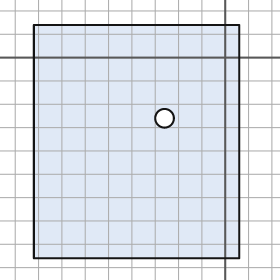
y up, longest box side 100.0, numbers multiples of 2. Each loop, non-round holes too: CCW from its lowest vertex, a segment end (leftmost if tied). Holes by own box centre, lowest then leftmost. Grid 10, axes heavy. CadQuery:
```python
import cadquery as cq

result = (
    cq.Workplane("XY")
    .moveTo(-82.0, -86.0)
    .lineTo(6.0, -86.0)
    .lineTo(6.0, 14.0)
    .lineTo(-82.0, 14.0)
    .close()
    .moveTo(-26.0, -26.0)
    .circle(4.0)
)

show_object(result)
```